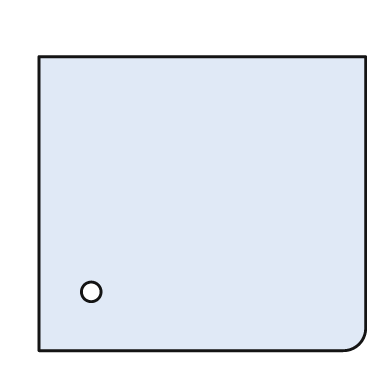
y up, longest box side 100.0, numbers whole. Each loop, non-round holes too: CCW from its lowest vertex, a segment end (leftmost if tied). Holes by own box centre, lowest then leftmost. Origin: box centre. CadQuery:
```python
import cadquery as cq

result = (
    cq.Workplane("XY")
    .moveTo(-50.0, -45.0)
    .lineTo(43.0, -45.0)
    .threePointArc((48.0, -43.0), (50.0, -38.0))
    .lineTo(50.0, 45.0)
    .lineTo(-50.0, 45.0)
    .close()
    .moveTo(-34.0, -27.0)
    .circle(3.0)
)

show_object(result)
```